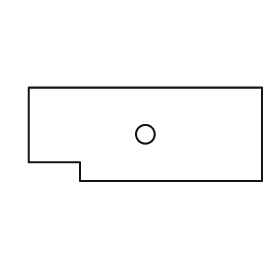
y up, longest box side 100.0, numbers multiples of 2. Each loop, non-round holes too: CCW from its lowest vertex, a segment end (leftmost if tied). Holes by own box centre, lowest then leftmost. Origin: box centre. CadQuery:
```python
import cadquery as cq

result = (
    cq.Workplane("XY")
    .moveTo(-28.0, -20.0)
    .lineTo(50.0, -20.0)
    .lineTo(50.0, 20.0)
    .lineTo(-50.0, 20.0)
    .lineTo(-50.0, -12.0)
    .lineTo(-28.0, -12.0)
    .close()
    .moveTo(0.0, 0.0)
    .circle(4.0)
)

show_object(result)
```